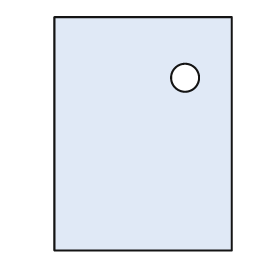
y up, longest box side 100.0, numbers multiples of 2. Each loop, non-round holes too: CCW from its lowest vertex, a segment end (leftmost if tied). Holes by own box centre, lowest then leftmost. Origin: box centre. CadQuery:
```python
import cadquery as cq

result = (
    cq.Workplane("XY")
    .moveTo(-38.0, -50.0)
    .lineTo(38.0, -50.0)
    .lineTo(38.0, 50.0)
    .lineTo(-38.0, 50.0)
    .close()
    .moveTo(18.0, 24.0)
    .circle(6.0)
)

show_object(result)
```